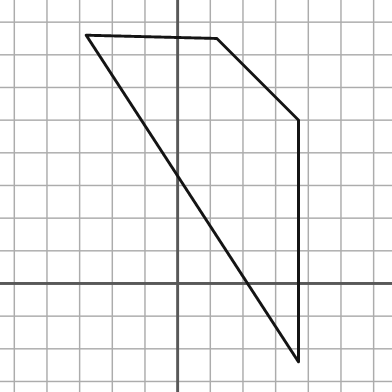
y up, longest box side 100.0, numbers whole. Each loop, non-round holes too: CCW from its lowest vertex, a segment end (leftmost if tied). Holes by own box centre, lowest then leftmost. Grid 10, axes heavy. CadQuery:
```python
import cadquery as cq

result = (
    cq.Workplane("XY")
    .moveTo(37.0, -24.0)
    .lineTo(37.0, 50.0)
    .lineTo(12.0, 75.0)
    .lineTo(-28.0, 76.0)
    .close()
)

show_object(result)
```